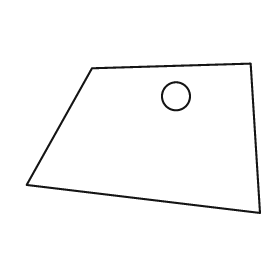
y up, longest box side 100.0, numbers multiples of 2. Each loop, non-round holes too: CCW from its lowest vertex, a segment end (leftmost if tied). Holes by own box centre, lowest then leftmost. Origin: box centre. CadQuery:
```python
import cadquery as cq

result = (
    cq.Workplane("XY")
    .moveTo(50.0, -32.0)
    .lineTo(46.0, 32.0)
    .lineTo(-22.0, 30.0)
    .lineTo(-50.0, -20.0)
    .close()
    .moveTo(14.0, 18.0)
    .circle(6.0)
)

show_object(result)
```